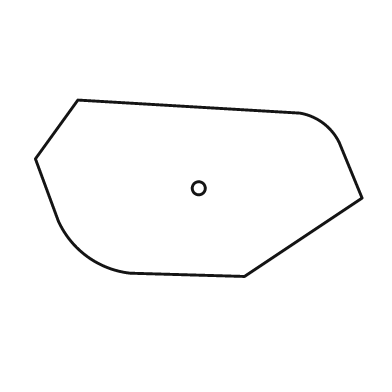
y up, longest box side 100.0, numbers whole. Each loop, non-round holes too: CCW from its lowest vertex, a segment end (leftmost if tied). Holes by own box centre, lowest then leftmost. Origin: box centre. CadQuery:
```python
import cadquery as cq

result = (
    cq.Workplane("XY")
    .moveTo(14.0, -27.0)
    .lineTo(50.0, -3.0)
    .lineTo(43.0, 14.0)
    .threePointArc((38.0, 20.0), (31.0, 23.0))
    .lineTo(-37.0, 27.0)
    .lineTo(-50.0, 9.0)
    .lineTo(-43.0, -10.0)
    .threePointArc((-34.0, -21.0), (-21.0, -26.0))
    .close()
    .moveTo(0.0, 0.0)
    .circle(2.0)
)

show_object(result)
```